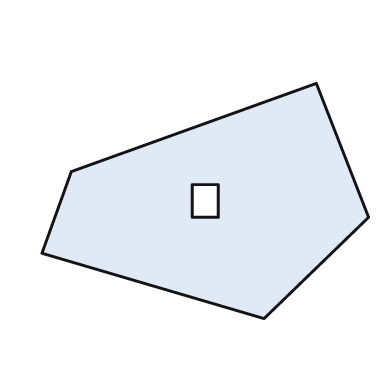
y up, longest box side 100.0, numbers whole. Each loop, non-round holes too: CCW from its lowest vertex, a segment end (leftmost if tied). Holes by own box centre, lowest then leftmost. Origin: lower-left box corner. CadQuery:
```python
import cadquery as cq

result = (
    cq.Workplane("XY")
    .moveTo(68.0, 0.0)
    .lineTo(100.0, 31.0)
    .lineTo(84.0, 72.0)
    .lineTo(9.0, 45.0)
    .lineTo(0.0, 20.0)
    .close()
    .moveTo(46.0, 31.0)
    .lineTo(54.0, 31.0)
    .lineTo(54.0, 41.0)
    .lineTo(46.0, 41.0)
    .close()
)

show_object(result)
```